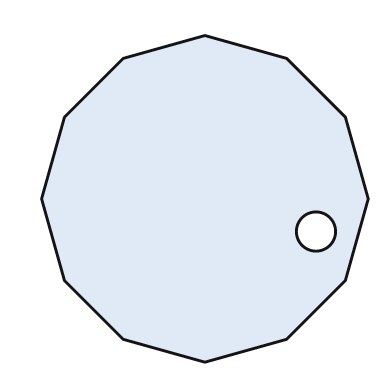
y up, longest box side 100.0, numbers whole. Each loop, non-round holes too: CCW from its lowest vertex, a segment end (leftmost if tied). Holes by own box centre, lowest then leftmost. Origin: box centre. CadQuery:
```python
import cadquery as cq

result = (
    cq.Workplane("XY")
    .moveTo(0.0, -50.0)
    .lineTo(25.0, -43.0)
    .lineTo(43.0, -25.0)
    .lineTo(50.0, 0.0)
    .lineTo(43.0, 25.0)
    .lineTo(25.0, 43.0)
    .lineTo(0.0, 50.0)
    .lineTo(-25.0, 43.0)
    .lineTo(-43.0, 25.0)
    .lineTo(-50.0, 0.0)
    .lineTo(-43.0, -25.0)
    .lineTo(-25.0, -43.0)
    .close()
    .moveTo(34.0, -10.0)
    .circle(6.0)
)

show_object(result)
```